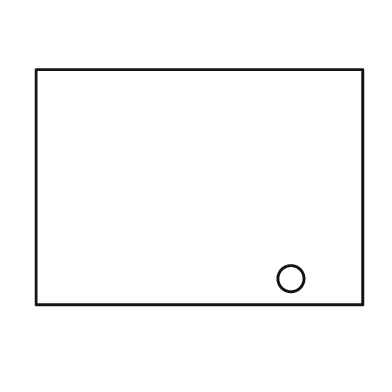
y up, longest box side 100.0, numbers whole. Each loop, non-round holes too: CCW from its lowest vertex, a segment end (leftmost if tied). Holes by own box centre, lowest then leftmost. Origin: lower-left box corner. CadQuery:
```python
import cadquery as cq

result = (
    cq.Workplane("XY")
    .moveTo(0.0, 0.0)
    .lineTo(100.0, 0.0)
    .lineTo(100.0, 72.0)
    .lineTo(0.0, 72.0)
    .close()
    .moveTo(78.0, 8.0)
    .circle(4.0)
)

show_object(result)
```